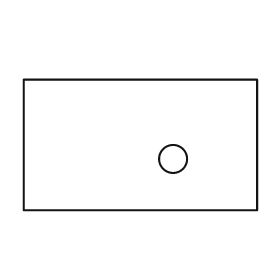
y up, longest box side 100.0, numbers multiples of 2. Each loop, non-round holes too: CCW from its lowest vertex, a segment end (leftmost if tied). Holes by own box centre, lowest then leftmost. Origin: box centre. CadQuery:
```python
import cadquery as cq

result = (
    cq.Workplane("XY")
    .moveTo(-50.0, -28.0)
    .lineTo(50.0, -28.0)
    .lineTo(50.0, 28.0)
    .lineTo(-50.0, 28.0)
    .close()
    .moveTo(14.0, -6.0)
    .circle(6.0)
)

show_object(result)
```